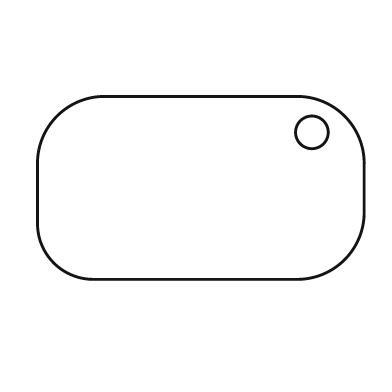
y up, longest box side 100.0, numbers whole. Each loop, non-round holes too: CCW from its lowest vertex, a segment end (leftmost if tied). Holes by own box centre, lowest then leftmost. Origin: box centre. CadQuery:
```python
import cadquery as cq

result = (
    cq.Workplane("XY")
    .moveTo(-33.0, -28.0)
    .lineTo(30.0, -28.0)
    .threePointArc((44.0, -22.0), (50.0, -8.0))
    .lineTo(50.0, 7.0)
    .threePointArc((44.0, 22.0), (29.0, 28.0))
    .lineTo(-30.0, 28.0)
    .threePointArc((-44.0, 22.0), (-50.0, 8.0))
    .lineTo(-50.0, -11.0)
    .threePointArc((-45.0, -23.0), (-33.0, -28.0))
    .close()
    .moveTo(34.0, 17.0)
    .circle(5.0)
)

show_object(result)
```